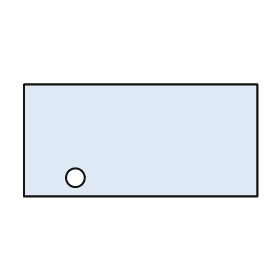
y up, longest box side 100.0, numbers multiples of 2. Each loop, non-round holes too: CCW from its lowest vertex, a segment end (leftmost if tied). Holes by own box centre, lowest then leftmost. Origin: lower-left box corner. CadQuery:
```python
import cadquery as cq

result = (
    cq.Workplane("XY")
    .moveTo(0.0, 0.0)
    .lineTo(100.0, 0.0)
    .lineTo(100.0, 48.0)
    .lineTo(0.0, 48.0)
    .close()
    .moveTo(22.0, 8.0)
    .circle(4.0)
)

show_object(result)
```